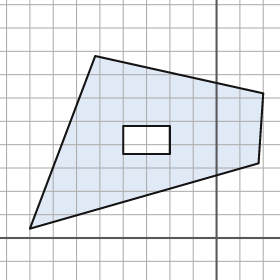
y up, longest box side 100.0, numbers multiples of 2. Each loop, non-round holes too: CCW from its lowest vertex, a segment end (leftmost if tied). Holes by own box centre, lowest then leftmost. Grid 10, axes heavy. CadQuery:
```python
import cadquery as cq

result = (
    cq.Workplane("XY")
    .moveTo(-80.0, 4.0)
    .lineTo(18.0, 32.0)
    .lineTo(20.0, 62.0)
    .lineTo(-52.0, 78.0)
    .close()
    .moveTo(-40.0, 36.0)
    .lineTo(-20.0, 36.0)
    .lineTo(-20.0, 48.0)
    .lineTo(-40.0, 48.0)
    .close()
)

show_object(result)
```